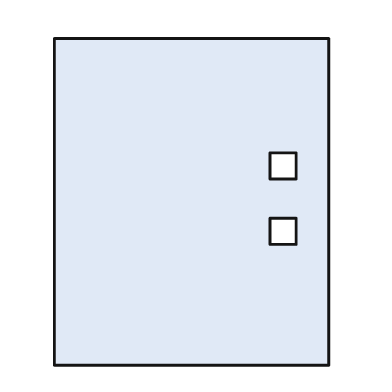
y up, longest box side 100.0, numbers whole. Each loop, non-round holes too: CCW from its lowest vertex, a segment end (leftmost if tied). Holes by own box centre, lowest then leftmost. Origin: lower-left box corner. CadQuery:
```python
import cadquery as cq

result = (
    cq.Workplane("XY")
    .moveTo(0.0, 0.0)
    .lineTo(84.0, 0.0)
    .lineTo(84.0, 100.0)
    .lineTo(0.0, 100.0)
    .close()
    .moveTo(66.0, 37.0)
    .lineTo(74.0, 37.0)
    .lineTo(74.0, 45.0)
    .lineTo(66.0, 45.0)
    .close()
    .moveTo(66.0, 57.0)
    .lineTo(74.0, 57.0)
    .lineTo(74.0, 65.0)
    .lineTo(66.0, 65.0)
    .close()
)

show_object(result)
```